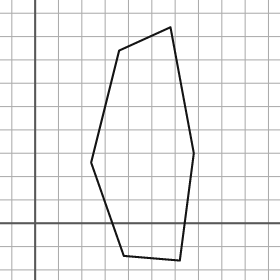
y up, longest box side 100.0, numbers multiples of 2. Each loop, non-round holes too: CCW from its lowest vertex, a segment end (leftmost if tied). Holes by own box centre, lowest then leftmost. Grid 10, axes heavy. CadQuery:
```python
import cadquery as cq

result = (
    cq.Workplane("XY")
    .moveTo(62.0, -16.0)
    .lineTo(68.0, 30.0)
    .lineTo(58.0, 84.0)
    .lineTo(36.0, 74.0)
    .lineTo(24.0, 26.0)
    .lineTo(38.0, -14.0)
    .close()
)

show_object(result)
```